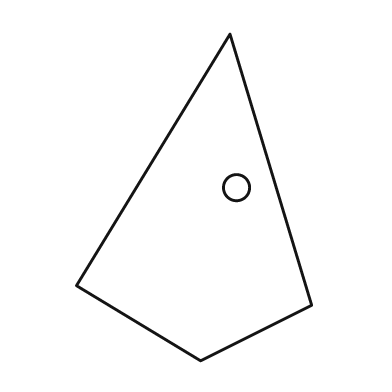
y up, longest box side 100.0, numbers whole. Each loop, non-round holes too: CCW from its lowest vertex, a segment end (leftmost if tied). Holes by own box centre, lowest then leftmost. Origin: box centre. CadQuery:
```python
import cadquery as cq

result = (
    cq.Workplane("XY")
    .moveTo(2.0, -50.0)
    .lineTo(36.0, -33.0)
    .lineTo(11.0, 50.0)
    .lineTo(-36.0, -27.0)
    .close()
    .moveTo(13.0, 3.0)
    .circle(4.0)
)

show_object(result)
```